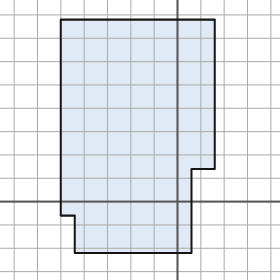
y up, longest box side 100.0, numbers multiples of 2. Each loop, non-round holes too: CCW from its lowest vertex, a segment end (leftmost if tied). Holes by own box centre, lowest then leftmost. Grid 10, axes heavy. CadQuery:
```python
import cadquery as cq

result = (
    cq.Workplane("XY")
    .moveTo(-44.0, -22.0)
    .lineTo(6.0, -22.0)
    .lineTo(6.0, 14.0)
    .lineTo(16.0, 14.0)
    .lineTo(16.0, 78.0)
    .lineTo(-50.0, 78.0)
    .lineTo(-50.0, -6.0)
    .lineTo(-44.0, -6.0)
    .close()
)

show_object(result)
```